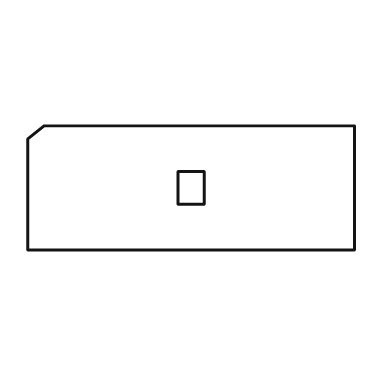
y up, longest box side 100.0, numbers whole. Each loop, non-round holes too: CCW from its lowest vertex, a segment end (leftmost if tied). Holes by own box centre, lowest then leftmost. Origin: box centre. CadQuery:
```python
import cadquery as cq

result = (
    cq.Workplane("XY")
    .moveTo(-50.0, -19.0)
    .lineTo(50.0, -19.0)
    .lineTo(50.0, 19.0)
    .lineTo(-45.0, 19.0)
    .lineTo(-50.0, 15.0)
    .close()
    .moveTo(-4.0, -5.0)
    .lineTo(4.0, -5.0)
    .lineTo(4.0, 5.0)
    .lineTo(-4.0, 5.0)
    .close()
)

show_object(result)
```